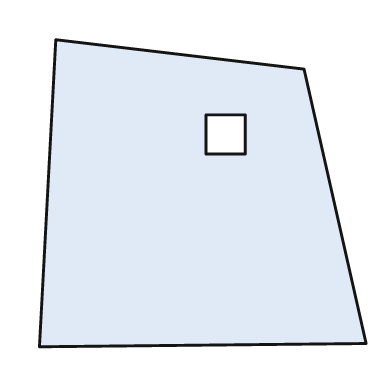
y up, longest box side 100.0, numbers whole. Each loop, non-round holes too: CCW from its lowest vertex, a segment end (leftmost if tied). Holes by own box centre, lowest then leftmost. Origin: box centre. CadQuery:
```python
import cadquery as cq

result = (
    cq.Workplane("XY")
    .moveTo(-50.0, -47.0)
    .lineTo(50.0, -46.0)
    .lineTo(31.0, 38.0)
    .lineTo(-45.0, 47.0)
    .close()
    .moveTo(1.0, 12.0)
    .lineTo(13.0, 12.0)
    .lineTo(13.0, 24.0)
    .lineTo(1.0, 24.0)
    .close()
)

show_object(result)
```